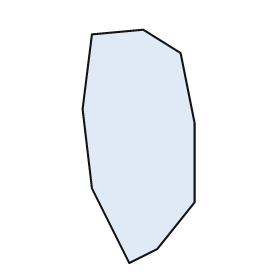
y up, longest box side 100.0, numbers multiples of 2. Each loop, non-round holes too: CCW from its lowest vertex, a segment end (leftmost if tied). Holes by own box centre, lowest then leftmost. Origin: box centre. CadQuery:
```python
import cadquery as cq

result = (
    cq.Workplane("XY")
    .moveTo(-4.0, -50.0)
    .lineTo(8.0, -44.0)
    .lineTo(24.0, -24.0)
    .lineTo(24.0, 10.0)
    .lineTo(18.0, 40.0)
    .lineTo(2.0, 50.0)
    .lineTo(-20.0, 48.0)
    .lineTo(-24.0, 16.0)
    .lineTo(-20.0, -18.0)
    .close()
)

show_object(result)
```